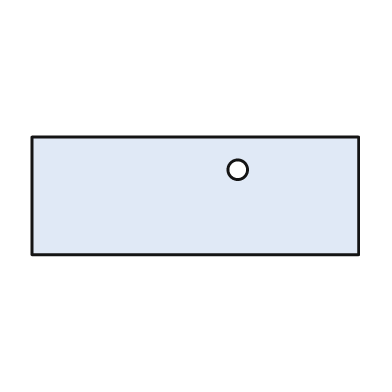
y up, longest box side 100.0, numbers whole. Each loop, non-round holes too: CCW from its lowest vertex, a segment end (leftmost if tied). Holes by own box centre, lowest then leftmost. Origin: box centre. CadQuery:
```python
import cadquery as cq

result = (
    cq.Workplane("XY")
    .moveTo(-50.0, -18.0)
    .lineTo(50.0, -18.0)
    .lineTo(50.0, 18.0)
    .lineTo(-50.0, 18.0)
    .close()
    .moveTo(13.0, 8.0)
    .circle(3.0)
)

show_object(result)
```